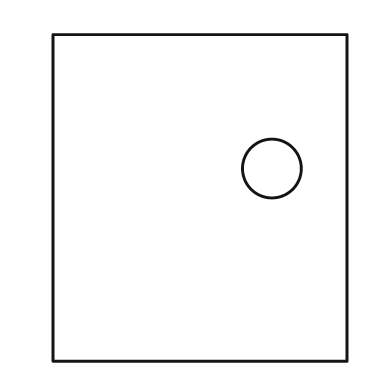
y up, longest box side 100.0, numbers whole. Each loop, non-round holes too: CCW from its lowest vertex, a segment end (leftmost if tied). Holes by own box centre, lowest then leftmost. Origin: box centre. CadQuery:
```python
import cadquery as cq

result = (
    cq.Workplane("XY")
    .moveTo(-45.0, -50.0)
    .lineTo(45.0, -50.0)
    .lineTo(45.0, 50.0)
    .lineTo(-45.0, 50.0)
    .close()
    .moveTo(22.0, 9.0)
    .circle(9.0)
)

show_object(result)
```